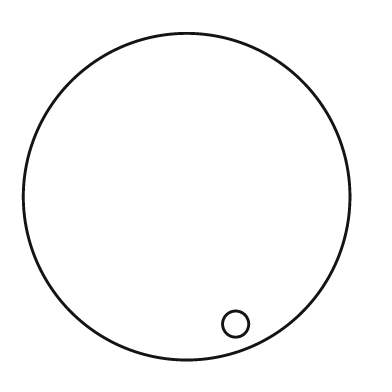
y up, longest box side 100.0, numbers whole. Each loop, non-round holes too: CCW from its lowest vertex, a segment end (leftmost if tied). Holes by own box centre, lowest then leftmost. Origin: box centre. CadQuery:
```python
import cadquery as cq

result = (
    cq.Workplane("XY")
    .moveTo(0.0, 0.0)
    .circle(50.0)
    .moveTo(15.0, -39.0)
    .circle(4.0)
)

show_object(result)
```